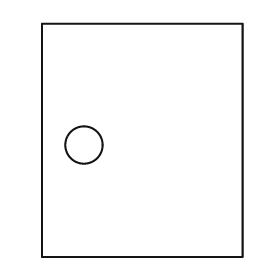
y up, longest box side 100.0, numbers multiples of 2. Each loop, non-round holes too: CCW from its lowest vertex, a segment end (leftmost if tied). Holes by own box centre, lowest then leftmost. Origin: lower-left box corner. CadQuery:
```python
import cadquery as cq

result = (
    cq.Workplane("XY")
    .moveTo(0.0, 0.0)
    .lineTo(86.0, 0.0)
    .lineTo(86.0, 100.0)
    .lineTo(0.0, 100.0)
    .close()
    .moveTo(18.0, 48.0)
    .circle(8.0)
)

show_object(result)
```